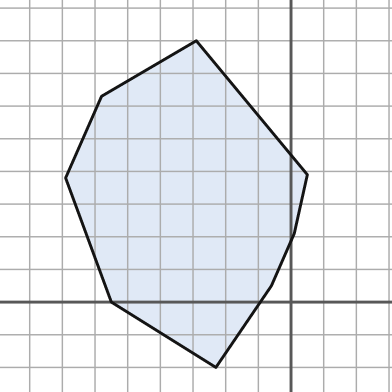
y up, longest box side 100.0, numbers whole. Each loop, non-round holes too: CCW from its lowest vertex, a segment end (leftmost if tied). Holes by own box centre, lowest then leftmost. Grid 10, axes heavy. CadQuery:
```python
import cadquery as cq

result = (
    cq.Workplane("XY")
    .moveTo(-23.0, -20.0)
    .lineTo(-6.0, 5.0)
    .lineTo(1.0, 21.0)
    .lineTo(5.0, 39.0)
    .lineTo(-29.0, 80.0)
    .lineTo(-58.0, 63.0)
    .lineTo(-69.0, 38.0)
    .lineTo(-55.0, 0.0)
    .close()
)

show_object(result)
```